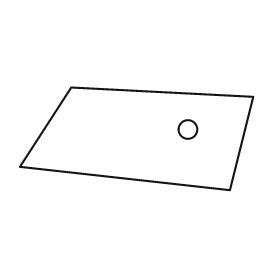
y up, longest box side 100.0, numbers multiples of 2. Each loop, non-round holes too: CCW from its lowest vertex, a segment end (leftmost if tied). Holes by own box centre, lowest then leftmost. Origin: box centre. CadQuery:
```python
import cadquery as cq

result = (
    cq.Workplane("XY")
    .moveTo(40.0, -22.0)
    .lineTo(50.0, 18.0)
    .lineTo(-28.0, 22.0)
    .lineTo(-50.0, -12.0)
    .close()
    .moveTo(22.0, 4.0)
    .circle(4.0)
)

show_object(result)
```